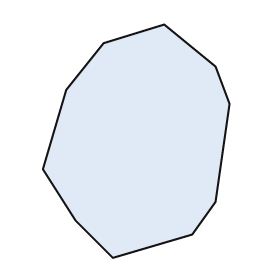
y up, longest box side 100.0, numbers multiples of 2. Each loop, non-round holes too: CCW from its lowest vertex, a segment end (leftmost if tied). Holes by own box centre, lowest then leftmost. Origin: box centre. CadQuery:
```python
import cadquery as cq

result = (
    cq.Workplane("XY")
    .moveTo(-10.0, -50.0)
    .lineTo(24.0, -40.0)
    .lineTo(34.0, -26.0)
    .lineTo(40.0, 16.0)
    .lineTo(34.0, 32.0)
    .lineTo(12.0, 50.0)
    .lineTo(-14.0, 42.0)
    .lineTo(-30.0, 22.0)
    .lineTo(-40.0, -12.0)
    .lineTo(-26.0, -34.0)
    .close()
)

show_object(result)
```